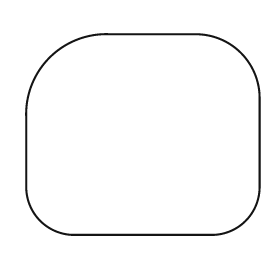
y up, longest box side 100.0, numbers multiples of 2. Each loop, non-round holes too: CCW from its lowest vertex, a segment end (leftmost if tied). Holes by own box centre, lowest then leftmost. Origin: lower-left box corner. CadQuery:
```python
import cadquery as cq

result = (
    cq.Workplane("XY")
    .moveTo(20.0, 0.0)
    .lineTo(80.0, 0.0)
    .threePointArc((94.0, 6.0), (100.0, 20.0))
    .lineTo(100.0, 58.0)
    .threePointArc((92.0, 78.0), (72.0, 86.0))
    .lineTo(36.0, 86.0)
    .threePointArc((10.0, 76.0), (0.0, 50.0))
    .lineTo(0.0, 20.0)
    .threePointArc((6.0, 6.0), (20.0, 0.0))
    .close()
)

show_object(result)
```